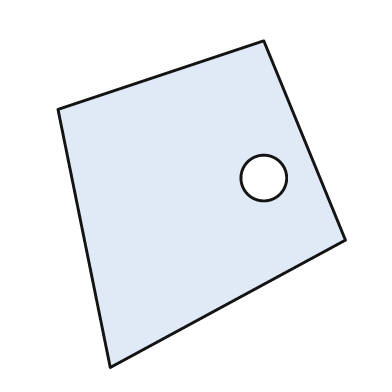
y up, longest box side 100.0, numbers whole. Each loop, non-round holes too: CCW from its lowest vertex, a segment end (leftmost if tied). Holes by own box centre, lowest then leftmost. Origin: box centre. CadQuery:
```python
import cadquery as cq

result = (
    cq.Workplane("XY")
    .moveTo(-28.0, -50.0)
    .lineTo(44.0, -11.0)
    .lineTo(19.0, 50.0)
    .lineTo(-44.0, 29.0)
    .close()
    .moveTo(19.0, 8.0)
    .circle(7.0)
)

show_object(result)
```